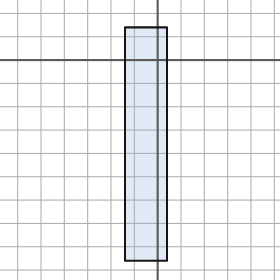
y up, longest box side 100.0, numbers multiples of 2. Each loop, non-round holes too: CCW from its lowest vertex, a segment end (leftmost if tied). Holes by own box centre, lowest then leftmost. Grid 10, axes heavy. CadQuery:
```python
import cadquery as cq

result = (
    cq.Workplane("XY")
    .moveTo(-14.0, -86.0)
    .lineTo(4.0, -86.0)
    .lineTo(4.0, 14.0)
    .lineTo(-14.0, 14.0)
    .close()
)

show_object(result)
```